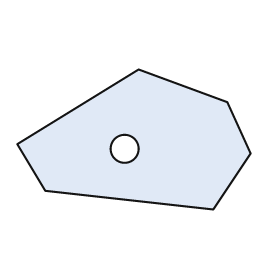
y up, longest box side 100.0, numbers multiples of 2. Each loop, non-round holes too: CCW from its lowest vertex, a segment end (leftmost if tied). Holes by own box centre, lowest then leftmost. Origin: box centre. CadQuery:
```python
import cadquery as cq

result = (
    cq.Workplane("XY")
    .moveTo(34.0, -30.0)
    .lineTo(50.0, -6.0)
    .lineTo(40.0, 16.0)
    .lineTo(2.0, 30.0)
    .lineTo(-50.0, -2.0)
    .lineTo(-38.0, -22.0)
    .close()
    .moveTo(-4.0, -4.0)
    .circle(6.0)
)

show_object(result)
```